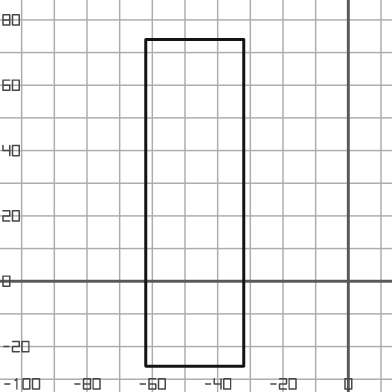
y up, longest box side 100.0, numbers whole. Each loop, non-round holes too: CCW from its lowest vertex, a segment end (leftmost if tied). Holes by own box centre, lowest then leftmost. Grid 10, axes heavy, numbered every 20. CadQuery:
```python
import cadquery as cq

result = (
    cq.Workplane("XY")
    .moveTo(-62.0, -26.0)
    .lineTo(-32.0, -26.0)
    .lineTo(-32.0, 74.0)
    .lineTo(-62.0, 74.0)
    .close()
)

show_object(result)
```